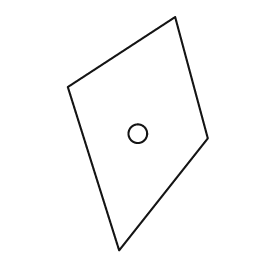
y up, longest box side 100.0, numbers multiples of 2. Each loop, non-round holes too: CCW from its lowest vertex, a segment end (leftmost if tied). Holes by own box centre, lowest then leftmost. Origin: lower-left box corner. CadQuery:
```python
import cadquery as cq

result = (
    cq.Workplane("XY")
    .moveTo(22.0, 0.0)
    .lineTo(60.0, 48.0)
    .lineTo(46.0, 100.0)
    .lineTo(0.0, 70.0)
    .close()
    .moveTo(30.0, 50.0)
    .circle(4.0)
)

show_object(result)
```